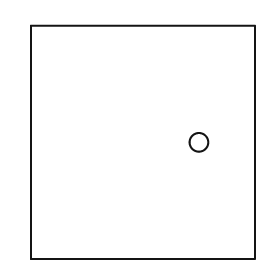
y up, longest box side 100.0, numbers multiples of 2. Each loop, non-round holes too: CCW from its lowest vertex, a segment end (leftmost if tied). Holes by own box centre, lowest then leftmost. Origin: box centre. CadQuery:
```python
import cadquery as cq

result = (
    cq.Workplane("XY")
    .moveTo(-48.0, -50.0)
    .lineTo(48.0, -50.0)
    .lineTo(48.0, 50.0)
    .lineTo(-48.0, 50.0)
    .close()
    .moveTo(24.0, 0.0)
    .circle(4.0)
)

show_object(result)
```